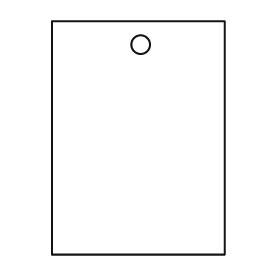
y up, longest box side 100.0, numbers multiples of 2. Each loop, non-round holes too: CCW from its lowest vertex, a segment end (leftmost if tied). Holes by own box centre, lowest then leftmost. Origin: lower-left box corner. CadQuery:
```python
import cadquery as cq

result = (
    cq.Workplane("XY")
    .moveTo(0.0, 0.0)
    .lineTo(74.0, 0.0)
    .lineTo(74.0, 100.0)
    .lineTo(0.0, 100.0)
    .close()
    .moveTo(38.0, 90.0)
    .circle(4.0)
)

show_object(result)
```